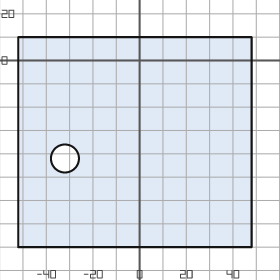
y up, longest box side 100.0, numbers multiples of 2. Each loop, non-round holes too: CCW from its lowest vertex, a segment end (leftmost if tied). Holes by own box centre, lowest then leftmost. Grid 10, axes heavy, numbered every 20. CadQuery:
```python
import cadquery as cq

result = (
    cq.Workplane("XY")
    .moveTo(-52.0, -80.0)
    .lineTo(48.0, -80.0)
    .lineTo(48.0, 10.0)
    .lineTo(-52.0, 10.0)
    .close()
    .moveTo(-32.0, -42.0)
    .circle(6.0)
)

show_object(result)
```